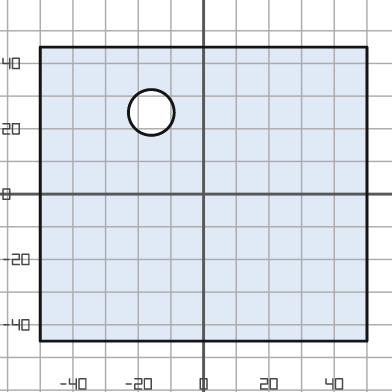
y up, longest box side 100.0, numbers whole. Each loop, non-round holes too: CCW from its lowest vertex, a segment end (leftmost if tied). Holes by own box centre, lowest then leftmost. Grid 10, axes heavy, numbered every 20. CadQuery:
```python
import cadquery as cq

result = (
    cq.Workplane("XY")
    .moveTo(-50.0, -45.0)
    .lineTo(50.0, -45.0)
    .lineTo(50.0, 45.0)
    .lineTo(-50.0, 45.0)
    .close()
    .moveTo(-16.0, 25.0)
    .circle(7.0)
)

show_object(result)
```